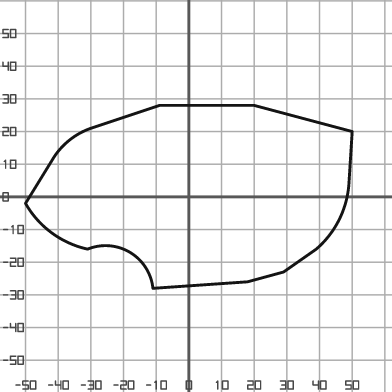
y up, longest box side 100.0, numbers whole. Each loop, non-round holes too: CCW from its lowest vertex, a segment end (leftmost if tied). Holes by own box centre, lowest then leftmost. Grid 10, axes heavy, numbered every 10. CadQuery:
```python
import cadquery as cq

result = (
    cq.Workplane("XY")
    .moveTo(-11.0, -28.0)
    .lineTo(18.0, -26.0)
    .lineTo(29.0, -23.0)
    .lineTo(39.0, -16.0)
    .threePointArc((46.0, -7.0), (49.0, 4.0))
    .lineTo(50.0, 20.0)
    .lineTo(20.0, 28.0)
    .lineTo(-9.0, 28.0)
    .lineTo(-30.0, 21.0)
    .threePointArc((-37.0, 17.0), (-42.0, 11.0))
    .lineTo(-50.0, -2.0)
    .threePointArc((-42.0, -11.0), (-31.0, -16.0))
    .threePointArc((-18.0, -17.0), (-11.0, -28.0))
    .close()
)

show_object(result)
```